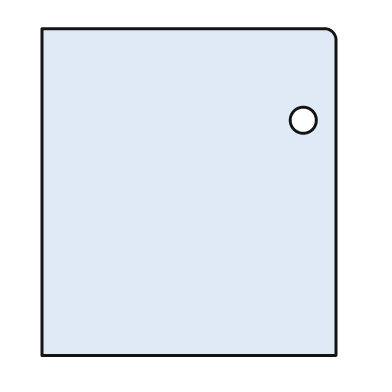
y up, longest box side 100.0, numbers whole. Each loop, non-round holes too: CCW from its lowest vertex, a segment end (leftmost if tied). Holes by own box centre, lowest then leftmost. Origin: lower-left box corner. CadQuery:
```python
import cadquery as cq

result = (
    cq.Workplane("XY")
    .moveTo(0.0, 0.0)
    .lineTo(90.0, 0.0)
    .lineTo(90.0, 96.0)
    .threePointArc((89.0, 99.0), (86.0, 100.0))
    .lineTo(0.0, 100.0)
    .close()
    .moveTo(80.0, 72.0)
    .circle(4.0)
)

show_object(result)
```